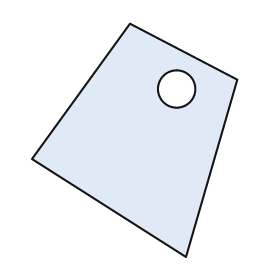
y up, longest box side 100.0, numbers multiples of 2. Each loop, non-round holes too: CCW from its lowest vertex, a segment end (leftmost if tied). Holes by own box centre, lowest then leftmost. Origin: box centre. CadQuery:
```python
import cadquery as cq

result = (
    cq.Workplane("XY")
    .moveTo(22.0, -50.0)
    .lineTo(44.0, 26.0)
    .lineTo(-2.0, 50.0)
    .lineTo(-44.0, -8.0)
    .close()
    .moveTo(18.0, 22.0)
    .circle(8.0)
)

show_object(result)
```